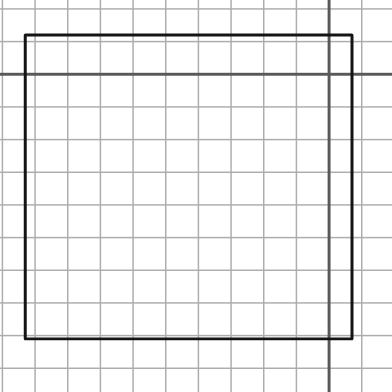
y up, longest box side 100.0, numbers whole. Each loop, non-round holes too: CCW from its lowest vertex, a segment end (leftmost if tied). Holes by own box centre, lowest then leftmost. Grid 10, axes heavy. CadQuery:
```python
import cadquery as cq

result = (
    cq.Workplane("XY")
    .moveTo(-93.0, -81.0)
    .lineTo(7.0, -81.0)
    .lineTo(7.0, 12.0)
    .lineTo(-93.0, 12.0)
    .close()
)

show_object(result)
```